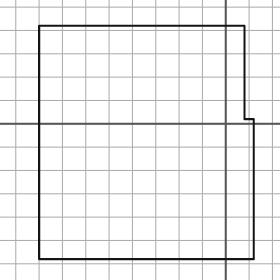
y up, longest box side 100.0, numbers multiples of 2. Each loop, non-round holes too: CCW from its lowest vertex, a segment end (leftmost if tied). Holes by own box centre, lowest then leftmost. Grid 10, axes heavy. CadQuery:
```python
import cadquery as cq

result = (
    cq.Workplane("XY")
    .moveTo(-80.0, -58.0)
    .lineTo(12.0, -58.0)
    .lineTo(12.0, 2.0)
    .lineTo(8.0, 2.0)
    .lineTo(8.0, 42.0)
    .lineTo(-80.0, 42.0)
    .close()
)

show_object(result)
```